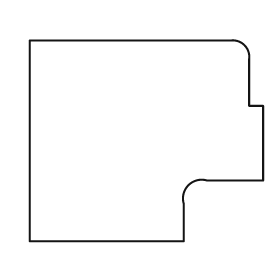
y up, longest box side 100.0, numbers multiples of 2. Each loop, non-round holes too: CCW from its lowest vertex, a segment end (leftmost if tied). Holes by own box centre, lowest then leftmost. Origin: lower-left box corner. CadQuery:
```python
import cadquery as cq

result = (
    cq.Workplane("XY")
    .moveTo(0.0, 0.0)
    .lineTo(66.0, 0.0)
    .lineTo(66.0, 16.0)
    .threePointArc((68.0, 24.0), (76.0, 26.0))
    .lineTo(100.0, 26.0)
    .lineTo(100.0, 58.0)
    .lineTo(94.0, 58.0)
    .lineTo(94.0, 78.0)
    .threePointArc((92.0, 84.0), (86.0, 86.0))
    .lineTo(0.0, 86.0)
    .close()
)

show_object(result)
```